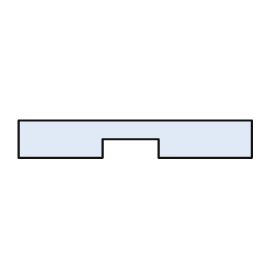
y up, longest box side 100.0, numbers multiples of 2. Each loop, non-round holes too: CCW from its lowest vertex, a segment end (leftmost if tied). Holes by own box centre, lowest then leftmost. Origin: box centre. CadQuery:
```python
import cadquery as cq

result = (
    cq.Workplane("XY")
    .moveTo(-50.0, -8.0)
    .lineTo(-14.0, -8.0)
    .lineTo(-14.0, 0.0)
    .lineTo(10.0, 0.0)
    .lineTo(10.0, -8.0)
    .lineTo(50.0, -8.0)
    .lineTo(50.0, 8.0)
    .lineTo(-50.0, 8.0)
    .close()
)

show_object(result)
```